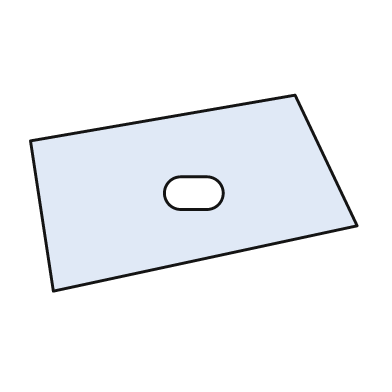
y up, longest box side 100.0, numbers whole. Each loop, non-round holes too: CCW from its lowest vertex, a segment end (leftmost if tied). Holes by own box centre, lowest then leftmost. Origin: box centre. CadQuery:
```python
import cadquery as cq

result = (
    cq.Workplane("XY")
    .moveTo(-43.0, -30.0)
    .lineTo(50.0, -10.0)
    .lineTo(31.0, 30.0)
    .lineTo(-50.0, 16.0)
    .close()
    .moveTo(-4.0, -5.0)
    .lineTo(4.0, -5.0)
    .threePointArc((9.0, 0.0), (4.0, 5.0))
    .lineTo(-4.0, 5.0)
    .threePointArc((-9.0, 0.0), (-4.0, -5.0))
    .close()
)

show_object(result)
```